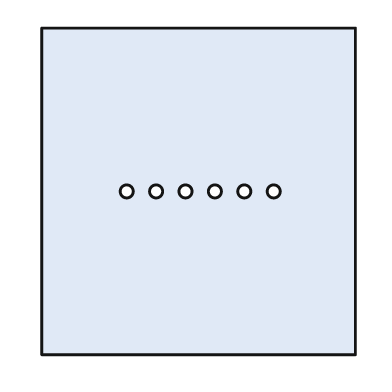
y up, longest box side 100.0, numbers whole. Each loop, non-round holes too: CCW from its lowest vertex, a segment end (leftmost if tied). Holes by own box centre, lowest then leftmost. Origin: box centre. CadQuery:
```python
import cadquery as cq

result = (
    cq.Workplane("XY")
    .moveTo(-48.0, -50.0)
    .lineTo(48.0, -50.0)
    .lineTo(48.0, 50.0)
    .lineTo(-48.0, 50.0)
    .close()
    .moveTo(-22.0, 0.0)
    .circle(2.0)
    .moveTo(-13.0, 0.0)
    .circle(2.0)
    .moveTo(-4.0, 0.0)
    .circle(2.0)
    .moveTo(5.0, 0.0)
    .circle(2.0)
    .moveTo(14.0, 0.0)
    .circle(2.0)
    .moveTo(23.0, 0.0)
    .circle(2.0)
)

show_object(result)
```